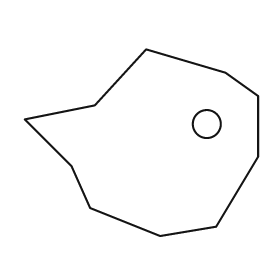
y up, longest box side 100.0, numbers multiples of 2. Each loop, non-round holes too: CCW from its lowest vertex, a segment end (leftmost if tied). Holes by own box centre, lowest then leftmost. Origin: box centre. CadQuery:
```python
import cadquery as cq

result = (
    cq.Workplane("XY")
    .moveTo(8.0, -40.0)
    .lineTo(32.0, -36.0)
    .lineTo(50.0, -6.0)
    .lineTo(50.0, 20.0)
    .lineTo(36.0, 30.0)
    .lineTo(2.0, 40.0)
    .lineTo(-20.0, 16.0)
    .lineTo(-50.0, 10.0)
    .lineTo(-30.0, -10.0)
    .lineTo(-22.0, -28.0)
    .close()
    .moveTo(28.0, 8.0)
    .circle(6.0)
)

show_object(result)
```